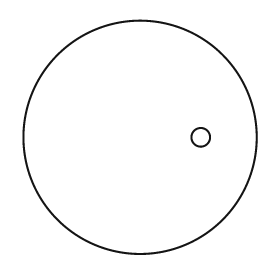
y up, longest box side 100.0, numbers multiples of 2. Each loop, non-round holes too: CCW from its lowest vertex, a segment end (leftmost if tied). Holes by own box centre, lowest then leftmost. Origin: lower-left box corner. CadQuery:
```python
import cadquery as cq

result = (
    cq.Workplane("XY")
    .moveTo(50.0, 50.0)
    .circle(50.0)
    .moveTo(76.0, 50.0)
    .circle(4.0)
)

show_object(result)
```